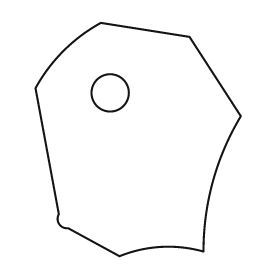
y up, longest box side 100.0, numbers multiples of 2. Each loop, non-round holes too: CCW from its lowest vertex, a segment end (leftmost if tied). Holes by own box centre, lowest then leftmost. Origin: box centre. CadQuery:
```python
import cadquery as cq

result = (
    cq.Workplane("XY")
    .moveTo(-8.0, -50.0)
    .threePointArc((10.0, -46.0), (28.0, -48.0))
    .threePointArc((32.0, -18.0), (44.0, 10.0))
    .lineTo(22.0, 44.0)
    .lineTo(-16.0, 50.0)
    .threePointArc((-32.0, 38.0), (-44.0, 22.0))
    .lineTo(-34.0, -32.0)
    .threePointArc((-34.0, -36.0), (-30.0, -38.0))
    .close()
    .moveTo(-12.0, 20.0)
    .circle(8.0)
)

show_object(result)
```